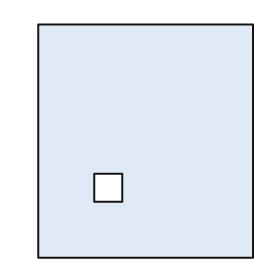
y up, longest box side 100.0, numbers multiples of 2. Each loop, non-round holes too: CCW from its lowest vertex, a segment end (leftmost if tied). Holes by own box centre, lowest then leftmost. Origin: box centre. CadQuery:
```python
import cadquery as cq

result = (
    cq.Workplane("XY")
    .moveTo(-46.0, -50.0)
    .lineTo(46.0, -50.0)
    .lineTo(46.0, 50.0)
    .lineTo(-46.0, 50.0)
    .close()
    .moveTo(-22.0, -26.0)
    .lineTo(-10.0, -26.0)
    .lineTo(-10.0, -14.0)
    .lineTo(-22.0, -14.0)
    .close()
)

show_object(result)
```